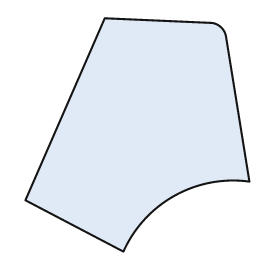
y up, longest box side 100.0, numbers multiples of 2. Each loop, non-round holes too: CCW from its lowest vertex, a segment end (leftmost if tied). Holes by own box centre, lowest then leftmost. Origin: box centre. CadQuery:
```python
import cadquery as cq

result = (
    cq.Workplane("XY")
    .moveTo(-6.0, -50.0)
    .threePointArc((16.0, -26.0), (48.0, -20.0))
    .lineTo(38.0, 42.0)
    .threePointArc((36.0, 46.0), (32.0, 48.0))
    .lineTo(-14.0, 50.0)
    .lineTo(-48.0, -28.0)
    .close()
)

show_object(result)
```